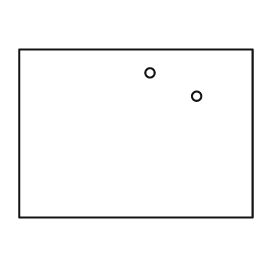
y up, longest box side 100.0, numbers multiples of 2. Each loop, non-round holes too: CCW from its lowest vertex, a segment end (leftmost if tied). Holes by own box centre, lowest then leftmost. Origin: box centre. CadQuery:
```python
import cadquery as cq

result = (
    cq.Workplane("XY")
    .moveTo(-50.0, -36.0)
    .lineTo(50.0, -36.0)
    .lineTo(50.0, 36.0)
    .lineTo(-50.0, 36.0)
    .close()
    .moveTo(26.0, 16.0)
    .circle(2.0)
    .moveTo(6.0, 26.0)
    .circle(2.0)
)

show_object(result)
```